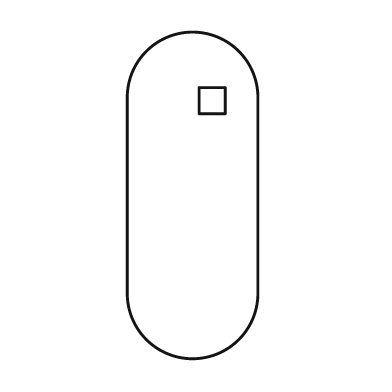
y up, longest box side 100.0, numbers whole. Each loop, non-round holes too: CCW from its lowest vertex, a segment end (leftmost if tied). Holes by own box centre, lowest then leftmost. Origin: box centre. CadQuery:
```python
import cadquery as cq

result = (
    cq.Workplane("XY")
    .moveTo(-20.0, -30.0)
    .threePointArc((0.0, -50.0), (20.0, -30.0))
    .lineTo(20.0, 30.0)
    .threePointArc((0.0, 50.0), (-20.0, 30.0))
    .close()
    .moveTo(2.0, 25.0)
    .lineTo(10.0, 25.0)
    .lineTo(10.0, 33.0)
    .lineTo(2.0, 33.0)
    .close()
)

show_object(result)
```